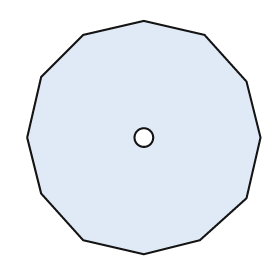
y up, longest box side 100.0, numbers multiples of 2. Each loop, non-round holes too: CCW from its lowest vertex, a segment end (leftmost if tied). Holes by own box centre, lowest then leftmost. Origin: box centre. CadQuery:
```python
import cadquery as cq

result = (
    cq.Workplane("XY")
    .moveTo(0.0, -50.0)
    .lineTo(24.0, -44.0)
    .lineTo(44.0, -26.0)
    .lineTo(50.0, 0.0)
    .lineTo(44.0, 24.0)
    .lineTo(26.0, 44.0)
    .lineTo(0.0, 50.0)
    .lineTo(-26.0, 44.0)
    .lineTo(-44.0, 26.0)
    .lineTo(-50.0, 0.0)
    .lineTo(-44.0, -24.0)
    .lineTo(-26.0, -44.0)
    .close()
    .moveTo(0.0, 0.0)
    .circle(4.0)
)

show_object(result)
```